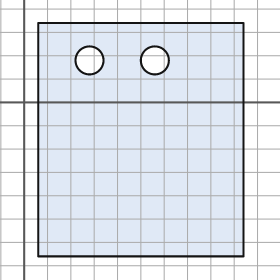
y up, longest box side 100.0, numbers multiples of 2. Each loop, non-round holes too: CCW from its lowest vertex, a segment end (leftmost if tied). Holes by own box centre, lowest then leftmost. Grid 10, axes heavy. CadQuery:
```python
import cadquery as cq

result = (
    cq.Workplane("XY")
    .moveTo(6.0, -66.0)
    .lineTo(94.0, -66.0)
    .lineTo(94.0, 34.0)
    .lineTo(6.0, 34.0)
    .close()
    .moveTo(28.0, 18.0)
    .circle(6.0)
    .moveTo(56.0, 18.0)
    .circle(6.0)
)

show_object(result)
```